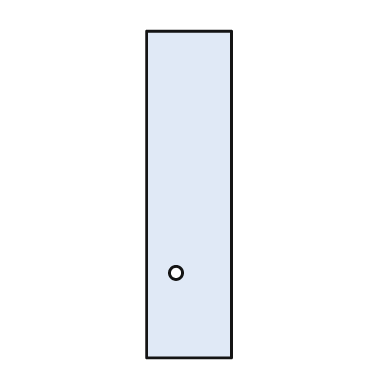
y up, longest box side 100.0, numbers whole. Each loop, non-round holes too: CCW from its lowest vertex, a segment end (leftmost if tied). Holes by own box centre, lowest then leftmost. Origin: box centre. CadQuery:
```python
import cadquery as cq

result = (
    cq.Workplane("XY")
    .moveTo(-13.0, -50.0)
    .lineTo(13.0, -50.0)
    .lineTo(13.0, 50.0)
    .lineTo(-13.0, 50.0)
    .close()
    .moveTo(-4.0, -24.0)
    .circle(2.0)
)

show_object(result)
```